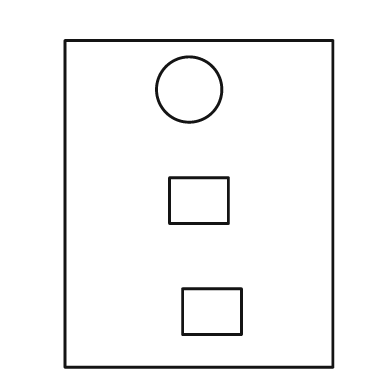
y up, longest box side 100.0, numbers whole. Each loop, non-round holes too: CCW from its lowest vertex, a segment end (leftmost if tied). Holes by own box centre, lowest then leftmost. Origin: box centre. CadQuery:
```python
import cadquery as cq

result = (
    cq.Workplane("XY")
    .moveTo(-41.0, -50.0)
    .lineTo(41.0, -50.0)
    .lineTo(41.0, 50.0)
    .lineTo(-41.0, 50.0)
    .close()
    .moveTo(-5.0, -40.0)
    .lineTo(13.0, -40.0)
    .lineTo(13.0, -26.0)
    .lineTo(-5.0, -26.0)
    .close()
    .moveTo(-9.0, -6.0)
    .lineTo(9.0, -6.0)
    .lineTo(9.0, 8.0)
    .lineTo(-9.0, 8.0)
    .close()
    .moveTo(-3.0, 35.0)
    .circle(10.0)
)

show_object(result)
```